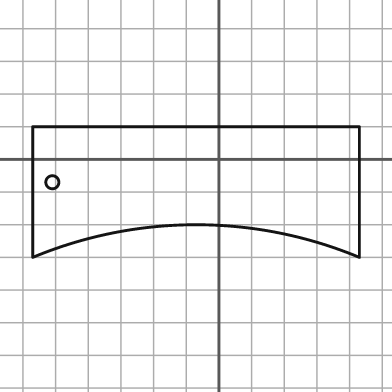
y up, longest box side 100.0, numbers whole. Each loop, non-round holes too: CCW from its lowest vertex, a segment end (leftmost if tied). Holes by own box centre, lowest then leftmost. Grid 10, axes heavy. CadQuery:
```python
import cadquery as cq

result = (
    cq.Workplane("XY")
    .moveTo(-57.0, -30.0)
    .threePointArc((-7.0, -20.0), (43.0, -30.0))
    .lineTo(43.0, 10.0)
    .lineTo(-57.0, 10.0)
    .close()
    .moveTo(-51.0, -7.0)
    .circle(2.0)
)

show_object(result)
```